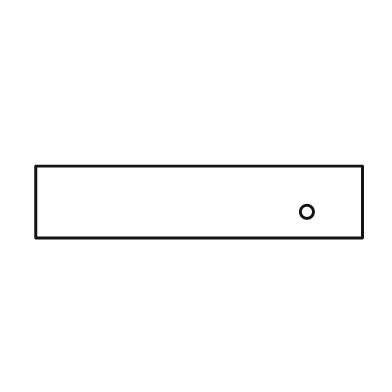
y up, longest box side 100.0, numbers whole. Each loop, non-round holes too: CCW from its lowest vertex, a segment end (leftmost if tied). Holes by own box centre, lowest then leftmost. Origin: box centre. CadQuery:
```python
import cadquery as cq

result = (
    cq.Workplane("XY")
    .moveTo(-50.0, -11.0)
    .lineTo(50.0, -11.0)
    .lineTo(50.0, 11.0)
    .lineTo(-50.0, 11.0)
    .close()
    .moveTo(33.0, -3.0)
    .circle(2.0)
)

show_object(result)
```